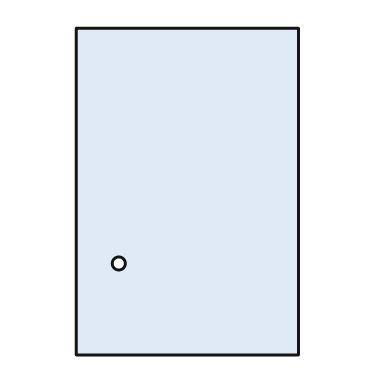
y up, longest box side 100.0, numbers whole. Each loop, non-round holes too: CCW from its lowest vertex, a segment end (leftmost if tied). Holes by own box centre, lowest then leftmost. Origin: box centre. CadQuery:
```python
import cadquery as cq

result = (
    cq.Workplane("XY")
    .moveTo(-34.0, -50.0)
    .lineTo(34.0, -50.0)
    .lineTo(34.0, 50.0)
    .lineTo(-34.0, 50.0)
    .close()
    .moveTo(-21.0, -22.0)
    .circle(2.0)
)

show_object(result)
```